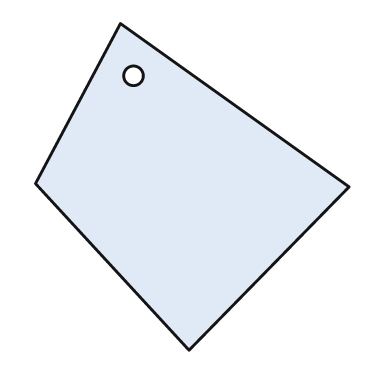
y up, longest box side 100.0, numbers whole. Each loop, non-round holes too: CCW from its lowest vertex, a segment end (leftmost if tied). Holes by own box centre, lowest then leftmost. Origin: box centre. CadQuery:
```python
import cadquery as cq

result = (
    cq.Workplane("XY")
    .moveTo(-1.0, -50.0)
    .lineTo(48.0, 0.0)
    .lineTo(-22.0, 50.0)
    .lineTo(-48.0, 1.0)
    .close()
    .moveTo(-18.0, 34.0)
    .circle(3.0)
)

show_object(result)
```